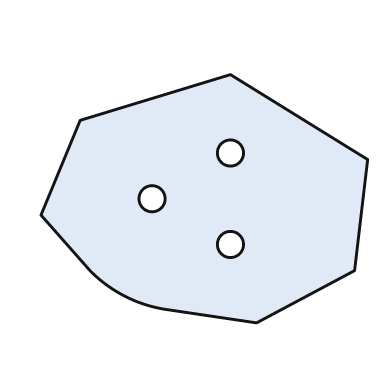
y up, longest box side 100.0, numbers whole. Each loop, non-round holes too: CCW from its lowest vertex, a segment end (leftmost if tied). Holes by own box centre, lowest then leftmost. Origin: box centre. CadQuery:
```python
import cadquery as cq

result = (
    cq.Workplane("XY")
    .moveTo(16.0, -38.0)
    .lineTo(46.0, -22.0)
    .lineTo(50.0, 12.0)
    .lineTo(8.0, 38.0)
    .lineTo(-38.0, 24.0)
    .lineTo(-50.0, -5.0)
    .lineTo(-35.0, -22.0)
    .threePointArc((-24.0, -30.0), (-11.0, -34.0))
    .close()
    .moveTo(8.0, -14.0)
    .circle(4.0)
    .moveTo(-16.0, 0.0)
    .circle(4.0)
    .moveTo(8.0, 14.0)
    .circle(4.0)
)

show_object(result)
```